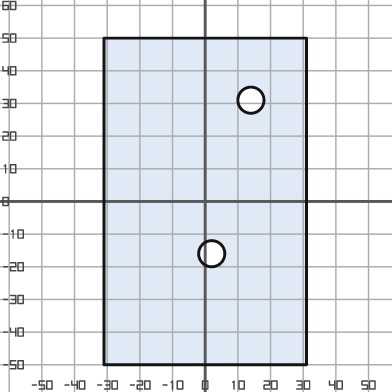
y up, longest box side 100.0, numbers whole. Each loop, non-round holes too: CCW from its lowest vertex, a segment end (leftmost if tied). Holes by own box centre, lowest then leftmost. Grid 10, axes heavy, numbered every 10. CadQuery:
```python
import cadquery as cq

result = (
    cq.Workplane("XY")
    .moveTo(-31.0, -50.0)
    .lineTo(31.0, -50.0)
    .lineTo(31.0, 50.0)
    .lineTo(-31.0, 50.0)
    .close()
    .moveTo(2.0, -16.0)
    .circle(4.0)
    .moveTo(14.0, 31.0)
    .circle(4.0)
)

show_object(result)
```